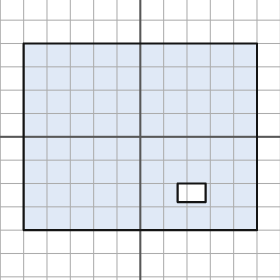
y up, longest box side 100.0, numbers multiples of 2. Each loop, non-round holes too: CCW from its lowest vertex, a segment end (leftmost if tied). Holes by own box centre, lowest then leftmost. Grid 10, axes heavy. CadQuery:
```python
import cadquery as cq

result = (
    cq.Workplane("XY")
    .moveTo(-50.0, -40.0)
    .lineTo(50.0, -40.0)
    .lineTo(50.0, 40.0)
    .lineTo(-50.0, 40.0)
    .close()
    .moveTo(16.0, -28.0)
    .lineTo(28.0, -28.0)
    .lineTo(28.0, -20.0)
    .lineTo(16.0, -20.0)
    .close()
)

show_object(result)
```